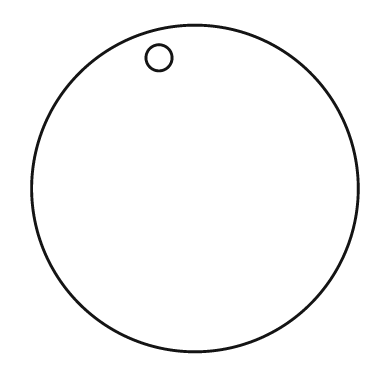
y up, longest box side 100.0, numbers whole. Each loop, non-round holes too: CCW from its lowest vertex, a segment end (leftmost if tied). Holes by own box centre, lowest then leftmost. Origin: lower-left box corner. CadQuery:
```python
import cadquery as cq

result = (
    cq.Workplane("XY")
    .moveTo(50.0, 50.0)
    .circle(50.0)
    .moveTo(39.0, 90.0)
    .circle(4.0)
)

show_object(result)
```